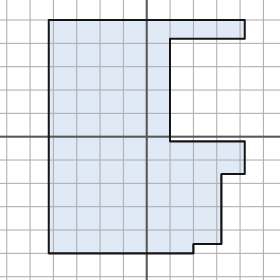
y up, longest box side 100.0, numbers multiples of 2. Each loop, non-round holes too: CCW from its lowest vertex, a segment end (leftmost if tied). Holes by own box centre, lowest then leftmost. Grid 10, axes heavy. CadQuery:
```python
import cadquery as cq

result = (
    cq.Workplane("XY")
    .moveTo(-42.0, -50.0)
    .lineTo(20.0, -50.0)
    .lineTo(20.0, -46.0)
    .lineTo(32.0, -46.0)
    .lineTo(32.0, -16.0)
    .lineTo(42.0, -16.0)
    .lineTo(42.0, -2.0)
    .lineTo(10.0, -2.0)
    .lineTo(10.0, 42.0)
    .lineTo(42.0, 42.0)
    .lineTo(42.0, 50.0)
    .lineTo(-42.0, 50.0)
    .close()
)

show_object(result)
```